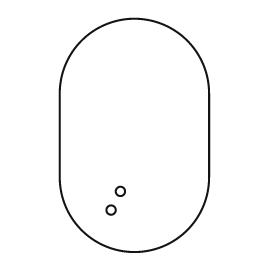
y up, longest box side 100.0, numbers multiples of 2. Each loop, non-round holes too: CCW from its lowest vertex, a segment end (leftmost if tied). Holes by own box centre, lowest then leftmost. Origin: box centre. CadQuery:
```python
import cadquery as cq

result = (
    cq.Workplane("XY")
    .moveTo(-32.0, -18.0)
    .threePointArc((0.0, -50.0), (32.0, -18.0))
    .lineTo(32.0, 18.0)
    .threePointArc((0.0, 50.0), (-32.0, 18.0))
    .close()
    .moveTo(-10.0, -32.0)
    .circle(2.0)
    .moveTo(-6.0, -24.0)
    .circle(2.0)
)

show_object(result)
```